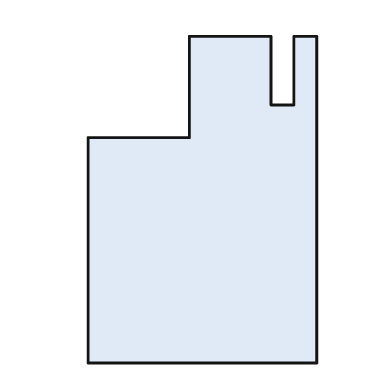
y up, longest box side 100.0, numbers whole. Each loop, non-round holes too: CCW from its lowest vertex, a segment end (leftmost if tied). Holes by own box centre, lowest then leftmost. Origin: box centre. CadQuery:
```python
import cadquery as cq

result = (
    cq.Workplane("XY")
    .moveTo(-35.0, -50.0)
    .lineTo(35.0, -50.0)
    .lineTo(35.0, 50.0)
    .lineTo(28.0, 50.0)
    .lineTo(28.0, 29.0)
    .lineTo(21.0, 29.0)
    .lineTo(21.0, 50.0)
    .lineTo(-4.0, 50.0)
    .lineTo(-4.0, 19.0)
    .lineTo(-35.0, 19.0)
    .close()
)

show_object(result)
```